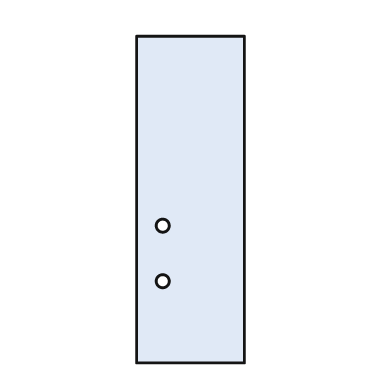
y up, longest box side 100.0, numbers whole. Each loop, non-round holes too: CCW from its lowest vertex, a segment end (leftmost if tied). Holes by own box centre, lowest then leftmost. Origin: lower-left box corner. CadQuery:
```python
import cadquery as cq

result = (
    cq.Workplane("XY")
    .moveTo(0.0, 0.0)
    .lineTo(33.0, 0.0)
    .lineTo(33.0, 100.0)
    .lineTo(0.0, 100.0)
    .close()
    .moveTo(8.0, 25.0)
    .circle(2.0)
    .moveTo(8.0, 42.0)
    .circle(2.0)
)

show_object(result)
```